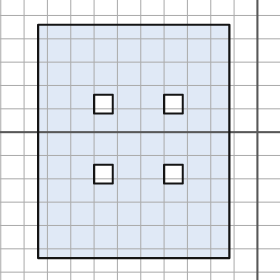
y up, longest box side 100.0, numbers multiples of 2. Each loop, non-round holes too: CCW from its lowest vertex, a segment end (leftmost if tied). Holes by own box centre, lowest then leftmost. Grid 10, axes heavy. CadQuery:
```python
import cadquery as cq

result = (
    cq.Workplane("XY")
    .moveTo(-94.0, -54.0)
    .lineTo(-12.0, -54.0)
    .lineTo(-12.0, 46.0)
    .lineTo(-94.0, 46.0)
    .close()
    .moveTo(-70.0, -22.0)
    .lineTo(-62.0, -22.0)
    .lineTo(-62.0, -14.0)
    .lineTo(-70.0, -14.0)
    .close()
    .moveTo(-40.0, -22.0)
    .lineTo(-32.0, -22.0)
    .lineTo(-32.0, -14.0)
    .lineTo(-40.0, -14.0)
    .close()
    .moveTo(-70.0, 8.0)
    .lineTo(-62.0, 8.0)
    .lineTo(-62.0, 16.0)
    .lineTo(-70.0, 16.0)
    .close()
    .moveTo(-40.0, 8.0)
    .lineTo(-32.0, 8.0)
    .lineTo(-32.0, 16.0)
    .lineTo(-40.0, 16.0)
    .close()
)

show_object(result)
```